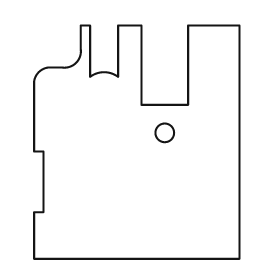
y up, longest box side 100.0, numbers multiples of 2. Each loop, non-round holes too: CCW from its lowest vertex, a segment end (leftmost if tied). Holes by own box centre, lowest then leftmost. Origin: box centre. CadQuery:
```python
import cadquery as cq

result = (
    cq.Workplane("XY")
    .moveTo(-44.0, -50.0)
    .lineTo(44.0, -50.0)
    .lineTo(44.0, 50.0)
    .lineTo(22.0, 50.0)
    .lineTo(22.0, 16.0)
    .lineTo(2.0, 16.0)
    .lineTo(2.0, 50.0)
    .lineTo(-8.0, 50.0)
    .lineTo(-8.0, 28.0)
    .threePointArc((-14.0, 30.0), (-20.0, 28.0))
    .lineTo(-20.0, 50.0)
    .lineTo(-24.0, 50.0)
    .lineTo(-24.0, 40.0)
    .threePointArc((-26.0, 34.0), (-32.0, 32.0))
    .lineTo(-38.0, 32.0)
    .threePointArc((-42.0, 30.0), (-44.0, 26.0))
    .lineTo(-44.0, -4.0)
    .lineTo(-40.0, -4.0)
    .lineTo(-40.0, -30.0)
    .lineTo(-44.0, -30.0)
    .close()
    .moveTo(12.0, 4.0)
    .circle(4.0)
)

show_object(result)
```